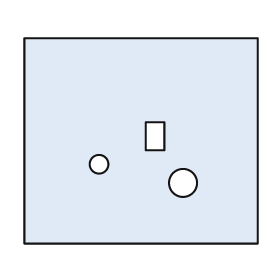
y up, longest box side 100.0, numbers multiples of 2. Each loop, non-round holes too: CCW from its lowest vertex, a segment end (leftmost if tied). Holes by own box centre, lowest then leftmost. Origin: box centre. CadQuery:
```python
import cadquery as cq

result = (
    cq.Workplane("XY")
    .moveTo(-50.0, -44.0)
    .lineTo(50.0, -44.0)
    .lineTo(50.0, 44.0)
    .lineTo(-50.0, 44.0)
    .close()
    .moveTo(18.0, -18.0)
    .circle(6.0)
    .moveTo(-18.0, -10.0)
    .circle(4.0)
    .moveTo(2.0, -4.0)
    .lineTo(10.0, -4.0)
    .lineTo(10.0, 8.0)
    .lineTo(2.0, 8.0)
    .close()
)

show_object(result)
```